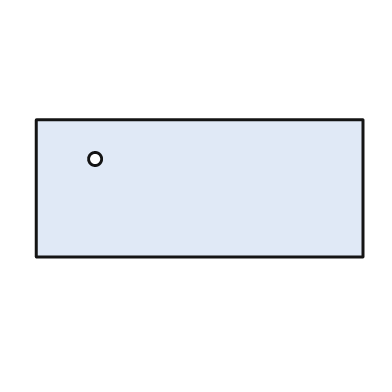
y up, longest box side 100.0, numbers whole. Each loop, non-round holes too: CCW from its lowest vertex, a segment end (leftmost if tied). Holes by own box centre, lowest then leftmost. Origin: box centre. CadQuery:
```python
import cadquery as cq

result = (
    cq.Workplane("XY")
    .moveTo(-50.0, -21.0)
    .lineTo(50.0, -21.0)
    .lineTo(50.0, 21.0)
    .lineTo(-50.0, 21.0)
    .close()
    .moveTo(-32.0, 9.0)
    .circle(2.0)
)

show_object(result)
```